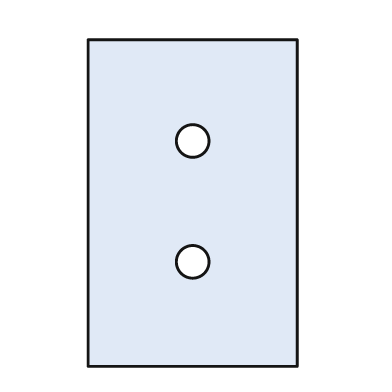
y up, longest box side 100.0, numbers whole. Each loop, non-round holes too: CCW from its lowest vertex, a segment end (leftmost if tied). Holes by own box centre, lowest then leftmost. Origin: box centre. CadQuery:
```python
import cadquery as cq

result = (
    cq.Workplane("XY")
    .moveTo(-32.0, -50.0)
    .lineTo(32.0, -50.0)
    .lineTo(32.0, 50.0)
    .lineTo(-32.0, 50.0)
    .close()
    .moveTo(0.0, -18.0)
    .circle(5.0)
    .moveTo(0.0, 19.0)
    .circle(5.0)
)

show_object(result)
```